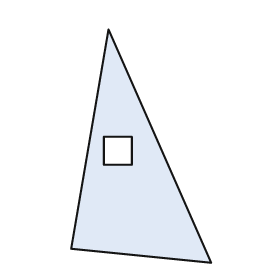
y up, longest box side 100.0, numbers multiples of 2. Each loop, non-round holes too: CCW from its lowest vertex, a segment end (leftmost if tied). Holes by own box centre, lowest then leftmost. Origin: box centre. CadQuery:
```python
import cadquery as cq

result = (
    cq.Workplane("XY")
    .moveTo(30.0, -50.0)
    .lineTo(-14.0, 50.0)
    .lineTo(-30.0, -44.0)
    .close()
    .moveTo(-16.0, -8.0)
    .lineTo(-4.0, -8.0)
    .lineTo(-4.0, 4.0)
    .lineTo(-16.0, 4.0)
    .close()
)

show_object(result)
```